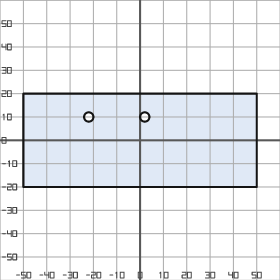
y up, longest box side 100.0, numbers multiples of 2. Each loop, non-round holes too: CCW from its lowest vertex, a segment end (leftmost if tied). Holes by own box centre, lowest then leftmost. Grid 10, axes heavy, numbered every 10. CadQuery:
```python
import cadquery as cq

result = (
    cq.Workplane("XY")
    .moveTo(-50.0, -20.0)
    .lineTo(50.0, -20.0)
    .lineTo(50.0, 20.0)
    .lineTo(-50.0, 20.0)
    .close()
    .moveTo(-22.0, 10.0)
    .circle(2.0)
    .moveTo(2.0, 10.0)
    .circle(2.0)
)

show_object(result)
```